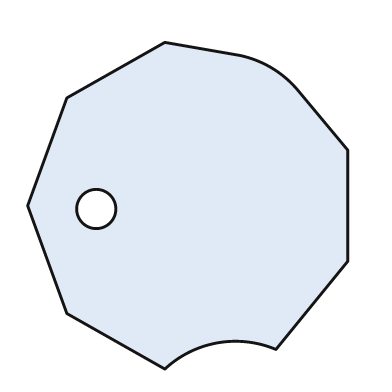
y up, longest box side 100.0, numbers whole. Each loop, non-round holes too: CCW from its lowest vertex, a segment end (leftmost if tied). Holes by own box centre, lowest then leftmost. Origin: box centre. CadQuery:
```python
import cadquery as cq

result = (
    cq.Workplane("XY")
    .moveTo(-7.0, -50.0)
    .threePointArc((9.0, -42.0), (27.0, -44.0))
    .lineTo(49.0, -17.0)
    .lineTo(49.0, 17.0)
    .lineTo(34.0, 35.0)
    .threePointArc((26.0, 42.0), (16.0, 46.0))
    .lineTo(-7.0, 50.0)
    .lineTo(-37.0, 33.0)
    .lineTo(-49.0, 0.0)
    .lineTo(-37.0, -33.0)
    .close()
    .moveTo(-28.0, -1.0)
    .circle(6.0)
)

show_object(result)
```